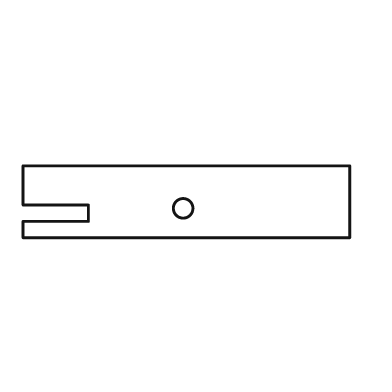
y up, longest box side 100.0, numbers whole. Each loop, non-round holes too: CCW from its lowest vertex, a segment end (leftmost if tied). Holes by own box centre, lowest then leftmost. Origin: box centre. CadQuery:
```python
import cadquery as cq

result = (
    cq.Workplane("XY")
    .moveTo(-50.0, -11.0)
    .lineTo(50.0, -11.0)
    .lineTo(50.0, 11.0)
    .lineTo(-50.0, 11.0)
    .lineTo(-50.0, -1.0)
    .lineTo(-30.0, -1.0)
    .lineTo(-30.0, -6.0)
    .lineTo(-50.0, -6.0)
    .close()
    .moveTo(-1.0, -2.0)
    .circle(3.0)
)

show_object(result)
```